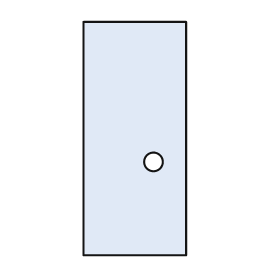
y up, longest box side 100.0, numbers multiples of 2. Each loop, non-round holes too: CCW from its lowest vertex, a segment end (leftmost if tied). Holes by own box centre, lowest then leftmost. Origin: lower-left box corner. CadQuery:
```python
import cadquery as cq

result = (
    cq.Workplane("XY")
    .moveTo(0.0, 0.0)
    .lineTo(44.0, 0.0)
    .lineTo(44.0, 100.0)
    .lineTo(0.0, 100.0)
    .close()
    .moveTo(30.0, 40.0)
    .circle(4.0)
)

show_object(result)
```